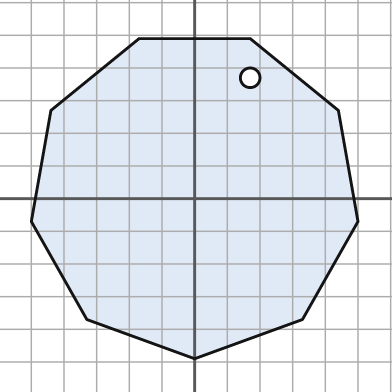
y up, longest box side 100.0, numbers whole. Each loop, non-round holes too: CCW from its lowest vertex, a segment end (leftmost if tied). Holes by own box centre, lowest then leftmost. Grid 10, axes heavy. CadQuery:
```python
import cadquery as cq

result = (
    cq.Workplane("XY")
    .moveTo(0.0, -49.0)
    .lineTo(33.0, -37.0)
    .lineTo(50.0, -7.0)
    .lineTo(44.0, 27.0)
    .lineTo(17.0, 49.0)
    .lineTo(-17.0, 49.0)
    .lineTo(-44.0, 27.0)
    .lineTo(-50.0, -7.0)
    .lineTo(-33.0, -37.0)
    .close()
    .moveTo(17.0, 37.0)
    .circle(3.0)
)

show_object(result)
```